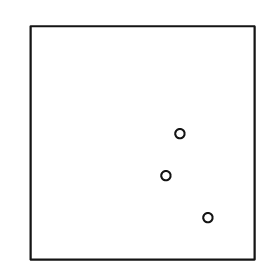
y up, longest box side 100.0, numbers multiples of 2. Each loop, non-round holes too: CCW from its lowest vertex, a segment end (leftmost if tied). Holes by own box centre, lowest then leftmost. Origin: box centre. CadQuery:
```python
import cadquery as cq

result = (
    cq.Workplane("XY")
    .moveTo(-48.0, -50.0)
    .lineTo(48.0, -50.0)
    .lineTo(48.0, 50.0)
    .lineTo(-48.0, 50.0)
    .close()
    .moveTo(28.0, -32.0)
    .circle(2.0)
    .moveTo(10.0, -14.0)
    .circle(2.0)
    .moveTo(16.0, 4.0)
    .circle(2.0)
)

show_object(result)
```